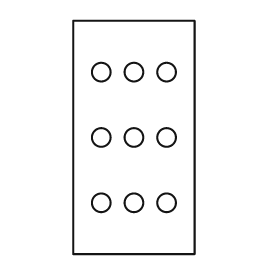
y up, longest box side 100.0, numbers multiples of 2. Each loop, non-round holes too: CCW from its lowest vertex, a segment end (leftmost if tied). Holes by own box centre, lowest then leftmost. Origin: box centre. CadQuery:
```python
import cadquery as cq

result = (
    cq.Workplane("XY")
    .moveTo(-26.0, -50.0)
    .lineTo(26.0, -50.0)
    .lineTo(26.0, 50.0)
    .lineTo(-26.0, 50.0)
    .close()
    .moveTo(-14.0, -28.0)
    .circle(4.0)
    .moveTo(0.0, -28.0)
    .circle(4.0)
    .moveTo(14.0, -28.0)
    .circle(4.0)
    .moveTo(-14.0, 0.0)
    .circle(4.0)
    .moveTo(0.0, 0.0)
    .circle(4.0)
    .moveTo(14.0, 0.0)
    .circle(4.0)
    .moveTo(-14.0, 28.0)
    .circle(4.0)
    .moveTo(0.0, 28.0)
    .circle(4.0)
    .moveTo(14.0, 28.0)
    .circle(4.0)
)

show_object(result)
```